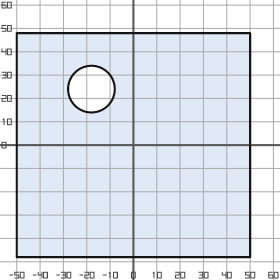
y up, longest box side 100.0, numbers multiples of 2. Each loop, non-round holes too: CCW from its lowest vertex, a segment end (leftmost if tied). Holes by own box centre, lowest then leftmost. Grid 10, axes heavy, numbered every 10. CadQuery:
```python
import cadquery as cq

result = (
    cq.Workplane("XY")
    .moveTo(-50.0, -48.0)
    .lineTo(50.0, -48.0)
    .lineTo(50.0, 48.0)
    .lineTo(-50.0, 48.0)
    .close()
    .moveTo(-18.0, 24.0)
    .circle(10.0)
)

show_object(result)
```